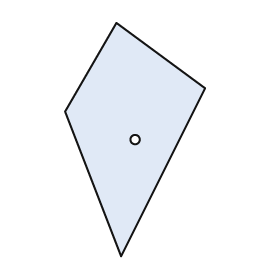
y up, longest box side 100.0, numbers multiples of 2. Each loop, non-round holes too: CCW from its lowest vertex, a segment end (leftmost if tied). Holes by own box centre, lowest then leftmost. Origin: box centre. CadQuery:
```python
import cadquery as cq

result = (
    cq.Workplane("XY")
    .moveTo(-6.0, -50.0)
    .lineTo(30.0, 22.0)
    .lineTo(-8.0, 50.0)
    .lineTo(-30.0, 12.0)
    .close()
    .moveTo(0.0, 0.0)
    .circle(2.0)
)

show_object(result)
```